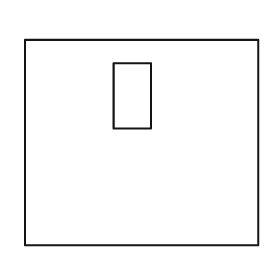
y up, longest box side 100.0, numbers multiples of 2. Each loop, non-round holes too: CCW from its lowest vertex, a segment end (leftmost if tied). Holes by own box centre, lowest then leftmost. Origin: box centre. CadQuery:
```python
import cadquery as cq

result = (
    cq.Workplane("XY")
    .moveTo(-50.0, -44.0)
    .lineTo(50.0, -44.0)
    .lineTo(50.0, 44.0)
    .lineTo(-50.0, 44.0)
    .close()
    .moveTo(-12.0, 6.0)
    .lineTo(4.0, 6.0)
    .lineTo(4.0, 34.0)
    .lineTo(-12.0, 34.0)
    .close()
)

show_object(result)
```